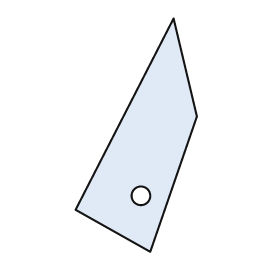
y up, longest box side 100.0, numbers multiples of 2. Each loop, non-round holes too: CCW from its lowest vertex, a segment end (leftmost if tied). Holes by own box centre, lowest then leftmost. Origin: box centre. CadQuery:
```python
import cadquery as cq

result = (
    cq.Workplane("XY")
    .moveTo(6.0, -50.0)
    .lineTo(26.0, 8.0)
    .lineTo(16.0, 50.0)
    .lineTo(-26.0, -32.0)
    .close()
    .moveTo(2.0, -26.0)
    .circle(4.0)
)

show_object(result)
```